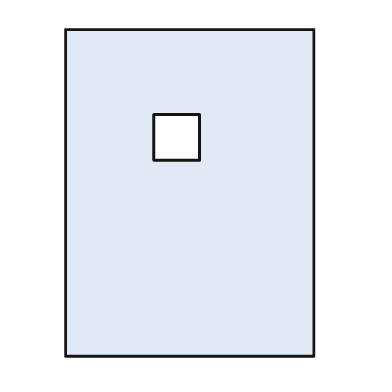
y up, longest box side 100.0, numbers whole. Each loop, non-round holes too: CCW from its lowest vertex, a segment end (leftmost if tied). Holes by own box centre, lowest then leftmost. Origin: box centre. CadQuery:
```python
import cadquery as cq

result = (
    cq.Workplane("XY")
    .moveTo(-38.0, -50.0)
    .lineTo(38.0, -50.0)
    .lineTo(38.0, 50.0)
    .lineTo(-38.0, 50.0)
    .close()
    .moveTo(-11.0, 10.0)
    .lineTo(3.0, 10.0)
    .lineTo(3.0, 24.0)
    .lineTo(-11.0, 24.0)
    .close()
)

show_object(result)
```